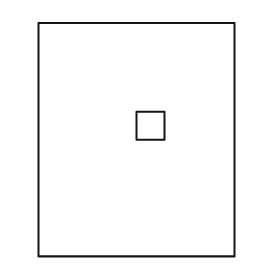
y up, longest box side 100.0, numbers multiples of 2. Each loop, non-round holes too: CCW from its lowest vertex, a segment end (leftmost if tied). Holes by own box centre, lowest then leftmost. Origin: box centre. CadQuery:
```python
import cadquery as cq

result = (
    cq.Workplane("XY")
    .moveTo(-42.0, -50.0)
    .lineTo(42.0, -50.0)
    .lineTo(42.0, 50.0)
    .lineTo(-42.0, 50.0)
    .close()
    .moveTo(0.0, 0.0)
    .lineTo(12.0, 0.0)
    .lineTo(12.0, 12.0)
    .lineTo(0.0, 12.0)
    .close()
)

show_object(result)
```